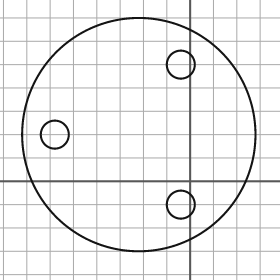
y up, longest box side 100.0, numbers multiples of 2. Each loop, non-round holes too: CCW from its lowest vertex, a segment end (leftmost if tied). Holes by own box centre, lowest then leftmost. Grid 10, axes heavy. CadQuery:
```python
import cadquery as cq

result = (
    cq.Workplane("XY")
    .moveTo(-22.0, 20.0)
    .circle(50.0)
    .moveTo(-4.0, -10.0)
    .circle(6.0)
    .moveTo(-58.0, 20.0)
    .circle(6.0)
    .moveTo(-4.0, 50.0)
    .circle(6.0)
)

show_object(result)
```